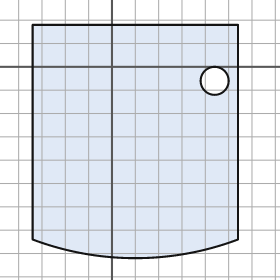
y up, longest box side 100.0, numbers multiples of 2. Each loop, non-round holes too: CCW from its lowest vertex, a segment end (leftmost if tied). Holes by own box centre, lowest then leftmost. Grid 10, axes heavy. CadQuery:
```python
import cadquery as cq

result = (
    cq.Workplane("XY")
    .moveTo(-34.0, -74.0)
    .threePointArc((10.0, -82.0), (54.0, -74.0))
    .lineTo(54.0, 18.0)
    .lineTo(-34.0, 18.0)
    .close()
    .moveTo(44.0, -6.0)
    .circle(6.0)
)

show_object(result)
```